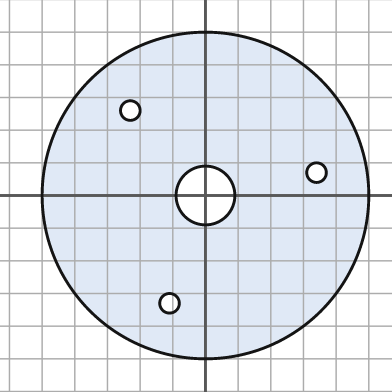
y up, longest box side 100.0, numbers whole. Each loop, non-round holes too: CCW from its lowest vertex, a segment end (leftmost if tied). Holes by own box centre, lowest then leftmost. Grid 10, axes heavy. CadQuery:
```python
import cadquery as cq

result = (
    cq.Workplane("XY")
    .moveTo(0.0, 0.0)
    .circle(50.0)
    .moveTo(-11.0, -33.0)
    .circle(3.0)
    .moveTo(0.0, 0.0)
    .circle(9.0)
    .moveTo(34.0, 7.0)
    .circle(3.0)
    .moveTo(-23.0, 26.0)
    .circle(3.0)
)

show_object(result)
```